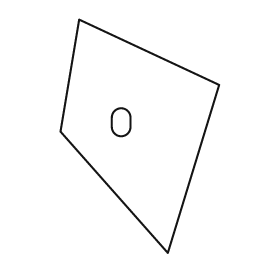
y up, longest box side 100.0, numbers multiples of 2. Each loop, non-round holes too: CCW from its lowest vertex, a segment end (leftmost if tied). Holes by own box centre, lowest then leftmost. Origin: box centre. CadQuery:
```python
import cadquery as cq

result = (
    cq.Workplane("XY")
    .moveTo(12.0, -50.0)
    .lineTo(34.0, 22.0)
    .lineTo(-26.0, 50.0)
    .lineTo(-34.0, 2.0)
    .close()
    .moveTo(-12.0, 4.0)
    .threePointArc((-8.0, 0.0), (-4.0, 4.0))
    .lineTo(-4.0, 8.0)
    .threePointArc((-8.0, 12.0), (-12.0, 8.0))
    .close()
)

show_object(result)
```